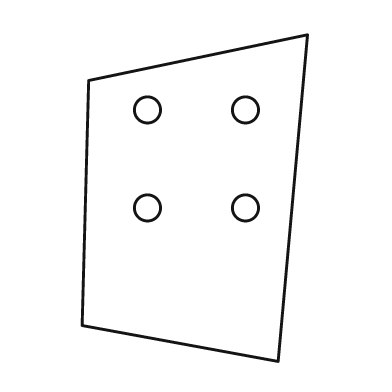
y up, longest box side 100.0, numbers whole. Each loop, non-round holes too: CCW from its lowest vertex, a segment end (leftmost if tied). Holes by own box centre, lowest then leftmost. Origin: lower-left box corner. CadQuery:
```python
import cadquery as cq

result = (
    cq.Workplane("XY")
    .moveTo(60.0, 0.0)
    .lineTo(69.0, 100.0)
    .lineTo(2.0, 86.0)
    .lineTo(0.0, 11.0)
    .close()
    .moveTo(20.0, 47.0)
    .circle(4.0)
    .moveTo(50.0, 47.0)
    .circle(4.0)
    .moveTo(20.0, 77.0)
    .circle(4.0)
    .moveTo(50.0, 77.0)
    .circle(4.0)
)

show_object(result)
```